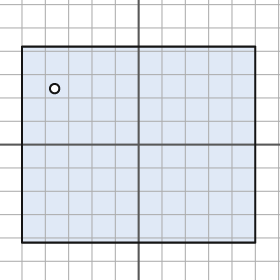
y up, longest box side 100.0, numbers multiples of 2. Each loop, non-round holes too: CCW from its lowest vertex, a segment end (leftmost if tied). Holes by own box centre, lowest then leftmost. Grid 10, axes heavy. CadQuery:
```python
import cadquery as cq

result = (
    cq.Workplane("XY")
    .moveTo(-50.0, -42.0)
    .lineTo(50.0, -42.0)
    .lineTo(50.0, 42.0)
    .lineTo(-50.0, 42.0)
    .close()
    .moveTo(-36.0, 24.0)
    .circle(2.0)
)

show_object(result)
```